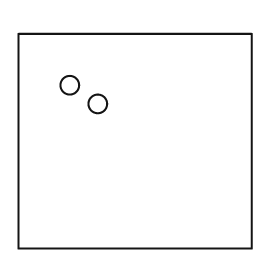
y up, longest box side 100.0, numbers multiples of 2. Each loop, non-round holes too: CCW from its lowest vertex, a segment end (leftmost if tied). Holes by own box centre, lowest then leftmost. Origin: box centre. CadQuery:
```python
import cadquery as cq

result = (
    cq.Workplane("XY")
    .moveTo(-50.0, -46.0)
    .lineTo(50.0, -46.0)
    .lineTo(50.0, 46.0)
    .lineTo(-50.0, 46.0)
    .close()
    .moveTo(-16.0, 16.0)
    .circle(4.0)
    .moveTo(-28.0, 24.0)
    .circle(4.0)
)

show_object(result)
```